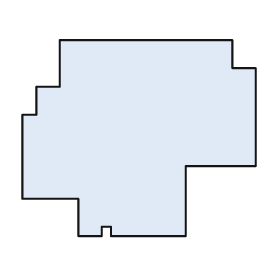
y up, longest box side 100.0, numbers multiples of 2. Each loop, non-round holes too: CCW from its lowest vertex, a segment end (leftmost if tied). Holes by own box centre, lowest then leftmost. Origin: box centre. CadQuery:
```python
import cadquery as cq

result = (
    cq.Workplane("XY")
    .moveTo(-26.0, -42.0)
    .lineTo(-16.0, -42.0)
    .lineTo(-16.0, -38.0)
    .lineTo(-12.0, -38.0)
    .lineTo(-12.0, -42.0)
    .lineTo(20.0, -42.0)
    .lineTo(20.0, -12.0)
    .lineTo(50.0, -12.0)
    .lineTo(50.0, 30.0)
    .lineTo(40.0, 30.0)
    .lineTo(40.0, 42.0)
    .lineTo(-34.0, 42.0)
    .lineTo(-34.0, 22.0)
    .lineTo(-44.0, 22.0)
    .lineTo(-44.0, 10.0)
    .lineTo(-50.0, 10.0)
    .lineTo(-50.0, -26.0)
    .lineTo(-26.0, -26.0)
    .close()
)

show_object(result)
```